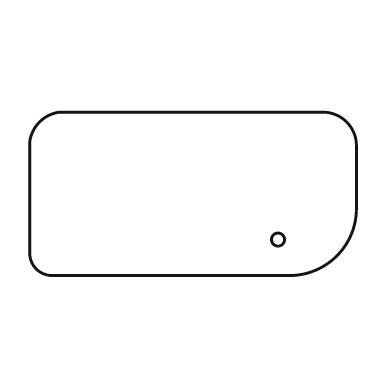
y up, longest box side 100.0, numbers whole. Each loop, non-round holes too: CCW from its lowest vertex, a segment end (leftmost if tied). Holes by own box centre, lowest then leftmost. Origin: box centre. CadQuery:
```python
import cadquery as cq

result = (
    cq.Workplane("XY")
    .moveTo(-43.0, -25.0)
    .lineTo(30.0, -25.0)
    .threePointArc((44.0, -19.0), (50.0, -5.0))
    .lineTo(50.0, 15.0)
    .threePointArc((47.0, 22.0), (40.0, 25.0))
    .lineTo(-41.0, 25.0)
    .threePointArc((-47.0, 22.0), (-50.0, 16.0))
    .lineTo(-50.0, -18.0)
    .threePointArc((-48.0, -23.0), (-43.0, -25.0))
    .close()
    .moveTo(26.0, -14.0)
    .circle(2.0)
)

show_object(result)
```